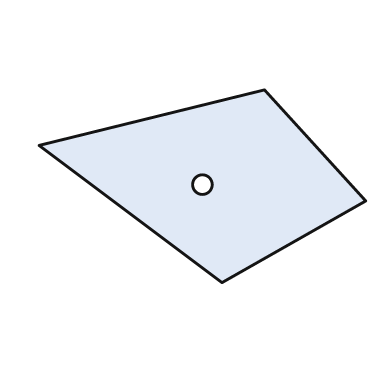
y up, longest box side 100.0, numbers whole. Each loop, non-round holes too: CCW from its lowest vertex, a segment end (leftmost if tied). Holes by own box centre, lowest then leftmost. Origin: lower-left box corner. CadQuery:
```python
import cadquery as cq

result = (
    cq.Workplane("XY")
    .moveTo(56.0, 0.0)
    .lineTo(100.0, 25.0)
    .lineTo(69.0, 59.0)
    .lineTo(0.0, 42.0)
    .close()
    .moveTo(50.0, 30.0)
    .circle(3.0)
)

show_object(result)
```